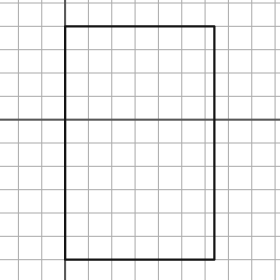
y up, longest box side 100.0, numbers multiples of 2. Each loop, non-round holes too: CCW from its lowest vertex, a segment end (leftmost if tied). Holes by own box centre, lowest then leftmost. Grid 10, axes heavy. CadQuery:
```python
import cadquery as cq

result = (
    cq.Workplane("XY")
    .moveTo(0.0, -60.0)
    .lineTo(64.0, -60.0)
    .lineTo(64.0, 40.0)
    .lineTo(0.0, 40.0)
    .close()
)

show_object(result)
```